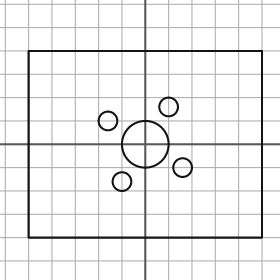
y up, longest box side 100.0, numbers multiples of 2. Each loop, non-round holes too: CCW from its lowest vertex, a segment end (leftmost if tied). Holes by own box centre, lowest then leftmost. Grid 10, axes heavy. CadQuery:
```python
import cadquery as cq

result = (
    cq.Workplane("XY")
    .moveTo(-50.0, -40.0)
    .lineTo(50.0, -40.0)
    .lineTo(50.0, 40.0)
    .lineTo(-50.0, 40.0)
    .close()
    .moveTo(-10.0, -16.0)
    .circle(4.0)
    .moveTo(16.0, -10.0)
    .circle(4.0)
    .moveTo(0.0, 0.0)
    .circle(10.0)
    .moveTo(-16.0, 10.0)
    .circle(4.0)
    .moveTo(10.0, 16.0)
    .circle(4.0)
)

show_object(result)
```